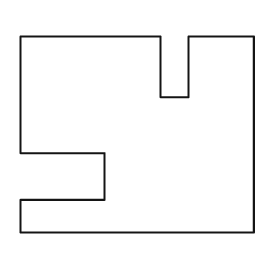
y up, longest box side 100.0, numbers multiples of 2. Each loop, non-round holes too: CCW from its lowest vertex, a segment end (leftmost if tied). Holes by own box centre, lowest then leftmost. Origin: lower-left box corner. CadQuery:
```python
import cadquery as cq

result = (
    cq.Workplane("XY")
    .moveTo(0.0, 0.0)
    .lineTo(100.0, 0.0)
    .lineTo(100.0, 84.0)
    .lineTo(72.0, 84.0)
    .lineTo(72.0, 58.0)
    .lineTo(60.0, 58.0)
    .lineTo(60.0, 84.0)
    .lineTo(0.0, 84.0)
    .lineTo(0.0, 34.0)
    .lineTo(36.0, 34.0)
    .lineTo(36.0, 14.0)
    .lineTo(0.0, 14.0)
    .close()
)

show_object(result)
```